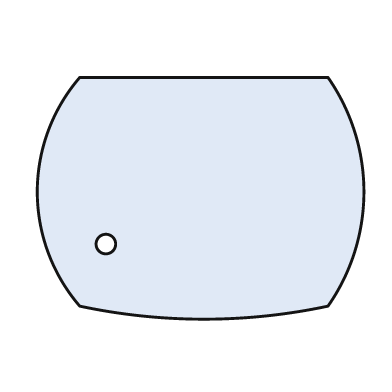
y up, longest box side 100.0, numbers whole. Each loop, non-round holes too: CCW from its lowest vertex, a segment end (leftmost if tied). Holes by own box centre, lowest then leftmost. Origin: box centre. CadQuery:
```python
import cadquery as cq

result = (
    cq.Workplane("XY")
    .moveTo(-37.0, -33.0)
    .threePointArc((1.0, -37.0), (39.0, -33.0))
    .threePointArc((50.0, 2.0), (39.0, 37.0))
    .lineTo(-37.0, 37.0)
    .threePointArc((-50.0, 2.0), (-37.0, -33.0))
    .close()
    .moveTo(-29.0, -14.0)
    .circle(3.0)
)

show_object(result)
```